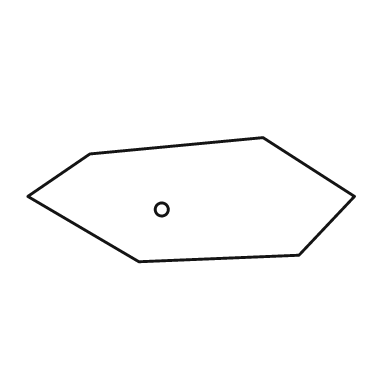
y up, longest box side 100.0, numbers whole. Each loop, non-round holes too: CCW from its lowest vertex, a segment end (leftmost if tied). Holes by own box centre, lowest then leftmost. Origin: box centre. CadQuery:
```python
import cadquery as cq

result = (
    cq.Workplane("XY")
    .moveTo(-16.0, -19.0)
    .lineTo(33.0, -17.0)
    .lineTo(50.0, 1.0)
    .lineTo(22.0, 19.0)
    .lineTo(-31.0, 14.0)
    .lineTo(-50.0, 1.0)
    .close()
    .moveTo(-9.0, -3.0)
    .circle(2.0)
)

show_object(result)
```